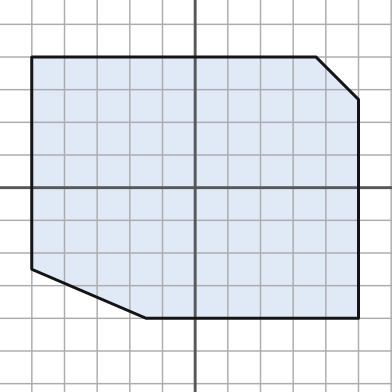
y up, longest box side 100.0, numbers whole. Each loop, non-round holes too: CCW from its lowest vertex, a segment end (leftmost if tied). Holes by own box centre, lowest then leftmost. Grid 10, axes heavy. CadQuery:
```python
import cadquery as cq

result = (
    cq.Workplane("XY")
    .moveTo(-15.0, -40.0)
    .lineTo(50.0, -40.0)
    .lineTo(50.0, 27.0)
    .lineTo(37.0, 40.0)
    .lineTo(-50.0, 40.0)
    .lineTo(-50.0, -25.0)
    .close()
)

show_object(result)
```